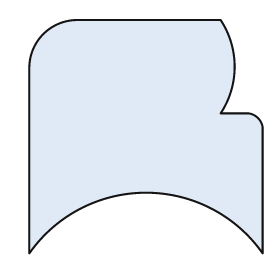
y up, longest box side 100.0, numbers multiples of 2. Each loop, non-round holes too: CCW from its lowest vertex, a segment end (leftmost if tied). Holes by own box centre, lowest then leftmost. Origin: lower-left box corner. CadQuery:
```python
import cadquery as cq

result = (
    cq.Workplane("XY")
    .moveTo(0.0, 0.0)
    .threePointArc((50.0, 26.0), (100.0, 0.0))
    .lineTo(100.0, 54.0)
    .threePointArc((98.0, 58.0), (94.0, 60.0))
    .lineTo(82.0, 60.0)
    .threePointArc((88.0, 80.0), (82.0, 100.0))
    .lineTo(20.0, 100.0)
    .threePointArc((6.0, 94.0), (0.0, 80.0))
    .close()
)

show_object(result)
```